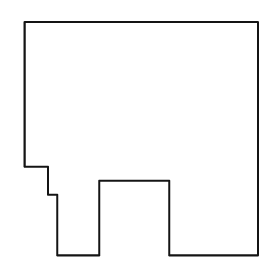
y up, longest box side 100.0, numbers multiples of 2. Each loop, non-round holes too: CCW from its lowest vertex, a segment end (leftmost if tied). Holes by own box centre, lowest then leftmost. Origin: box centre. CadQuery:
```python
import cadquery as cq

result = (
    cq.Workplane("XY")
    .moveTo(-36.0, -50.0)
    .lineTo(-18.0, -50.0)
    .lineTo(-18.0, -18.0)
    .lineTo(12.0, -18.0)
    .lineTo(12.0, -50.0)
    .lineTo(50.0, -50.0)
    .lineTo(50.0, 50.0)
    .lineTo(-50.0, 50.0)
    .lineTo(-50.0, -12.0)
    .lineTo(-40.0, -12.0)
    .lineTo(-40.0, -24.0)
    .lineTo(-36.0, -24.0)
    .close()
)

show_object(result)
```